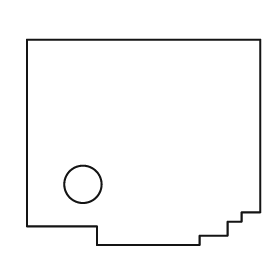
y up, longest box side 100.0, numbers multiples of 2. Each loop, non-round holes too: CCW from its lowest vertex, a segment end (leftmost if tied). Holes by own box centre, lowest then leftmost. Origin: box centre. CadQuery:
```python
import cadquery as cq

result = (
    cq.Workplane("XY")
    .moveTo(-20.0, -44.0)
    .lineTo(24.0, -44.0)
    .lineTo(24.0, -40.0)
    .lineTo(36.0, -40.0)
    .lineTo(36.0, -34.0)
    .lineTo(42.0, -34.0)
    .lineTo(42.0, -30.0)
    .lineTo(50.0, -30.0)
    .lineTo(50.0, 44.0)
    .lineTo(-50.0, 44.0)
    .lineTo(-50.0, -36.0)
    .lineTo(-20.0, -36.0)
    .close()
    .moveTo(-26.0, -18.0)
    .circle(8.0)
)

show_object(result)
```